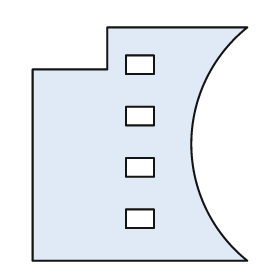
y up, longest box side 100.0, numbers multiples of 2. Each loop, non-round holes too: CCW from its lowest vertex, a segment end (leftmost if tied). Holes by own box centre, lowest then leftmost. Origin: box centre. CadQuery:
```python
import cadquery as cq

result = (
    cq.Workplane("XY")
    .moveTo(-46.0, -50.0)
    .lineTo(46.0, -50.0)
    .threePointArc((22.0, 0.0), (46.0, 50.0))
    .lineTo(-14.0, 50.0)
    .lineTo(-14.0, 32.0)
    .lineTo(-46.0, 32.0)
    .close()
    .moveTo(-6.0, -36.0)
    .lineTo(6.0, -36.0)
    .lineTo(6.0, -28.0)
    .lineTo(-6.0, -28.0)
    .close()
    .moveTo(-6.0, -14.0)
    .lineTo(6.0, -14.0)
    .lineTo(6.0, -6.0)
    .lineTo(-6.0, -6.0)
    .close()
    .moveTo(-6.0, 8.0)
    .lineTo(6.0, 8.0)
    .lineTo(6.0, 16.0)
    .lineTo(-6.0, 16.0)
    .close()
    .moveTo(-6.0, 30.0)
    .lineTo(6.0, 30.0)
    .lineTo(6.0, 38.0)
    .lineTo(-6.0, 38.0)
    .close()
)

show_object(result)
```